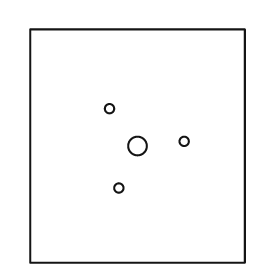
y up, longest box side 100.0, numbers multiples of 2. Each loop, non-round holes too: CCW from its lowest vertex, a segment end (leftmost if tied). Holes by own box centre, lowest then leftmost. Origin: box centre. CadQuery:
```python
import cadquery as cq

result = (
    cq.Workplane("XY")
    .moveTo(-46.0, -50.0)
    .lineTo(46.0, -50.0)
    .lineTo(46.0, 50.0)
    .lineTo(-46.0, 50.0)
    .close()
    .moveTo(-8.0, -18.0)
    .circle(2.0)
    .moveTo(0.0, 0.0)
    .circle(4.0)
    .moveTo(20.0, 2.0)
    .circle(2.0)
    .moveTo(-12.0, 16.0)
    .circle(2.0)
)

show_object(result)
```